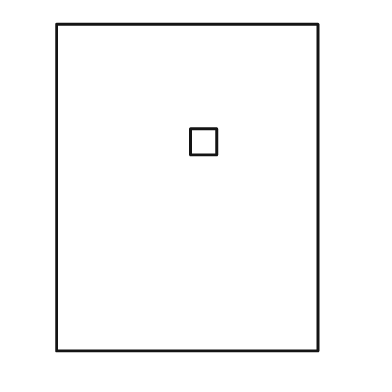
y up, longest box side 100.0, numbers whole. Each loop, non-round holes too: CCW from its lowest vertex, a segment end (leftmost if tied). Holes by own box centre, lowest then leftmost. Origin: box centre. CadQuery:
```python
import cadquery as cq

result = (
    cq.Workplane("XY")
    .moveTo(-40.0, -50.0)
    .lineTo(40.0, -50.0)
    .lineTo(40.0, 50.0)
    .lineTo(-40.0, 50.0)
    .close()
    .moveTo(1.0, 10.0)
    .lineTo(9.0, 10.0)
    .lineTo(9.0, 18.0)
    .lineTo(1.0, 18.0)
    .close()
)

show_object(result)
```